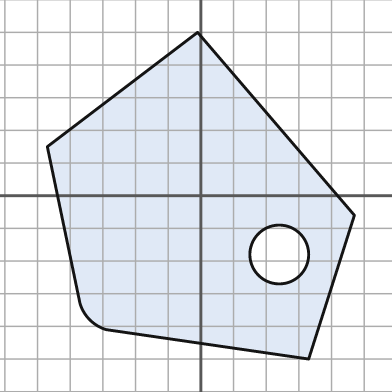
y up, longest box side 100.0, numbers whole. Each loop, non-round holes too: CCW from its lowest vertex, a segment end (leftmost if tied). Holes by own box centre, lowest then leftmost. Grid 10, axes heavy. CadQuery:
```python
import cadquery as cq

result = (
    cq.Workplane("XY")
    .moveTo(33.0, -50.0)
    .lineTo(47.0, -6.0)
    .lineTo(-1.0, 50.0)
    .lineTo(-47.0, 15.0)
    .lineTo(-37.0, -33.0)
    .threePointArc((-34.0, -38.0), (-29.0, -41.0))
    .close()
    .moveTo(24.0, -18.0)
    .circle(9.0)
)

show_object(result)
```